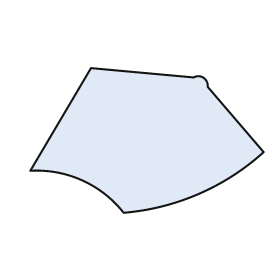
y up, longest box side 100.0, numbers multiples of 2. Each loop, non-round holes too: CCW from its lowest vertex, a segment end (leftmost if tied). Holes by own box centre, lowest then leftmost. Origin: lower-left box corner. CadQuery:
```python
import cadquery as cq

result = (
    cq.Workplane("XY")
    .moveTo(40.0, 0.0)
    .threePointArc((72.0, 8.0), (100.0, 26.0))
    .lineTo(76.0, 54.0)
    .threePointArc((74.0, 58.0), (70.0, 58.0))
    .lineTo(26.0, 62.0)
    .lineTo(0.0, 18.0)
    .threePointArc((22.0, 14.0), (40.0, 0.0))
    .close()
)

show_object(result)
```